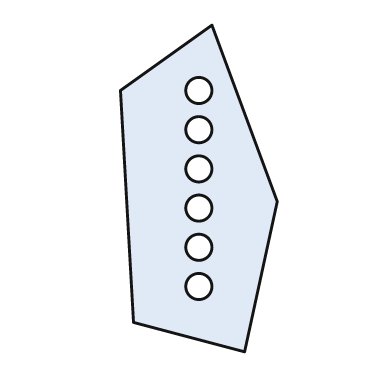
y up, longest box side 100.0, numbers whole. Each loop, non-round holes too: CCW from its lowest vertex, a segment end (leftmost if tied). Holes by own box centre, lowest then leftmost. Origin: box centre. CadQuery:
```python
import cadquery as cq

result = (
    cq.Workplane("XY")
    .moveTo(14.0, -50.0)
    .lineTo(24.0, -4.0)
    .lineTo(4.0, 50.0)
    .lineTo(-24.0, 30.0)
    .lineTo(-20.0, -41.0)
    .close()
    .moveTo(0.0, -30.0)
    .circle(4.0)
    .moveTo(0.0, -18.0)
    .circle(4.0)
    .moveTo(0.0, -6.0)
    .circle(4.0)
    .moveTo(0.0, 6.0)
    .circle(4.0)
    .moveTo(0.0, 18.0)
    .circle(4.0)
    .moveTo(0.0, 30.0)
    .circle(4.0)
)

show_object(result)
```